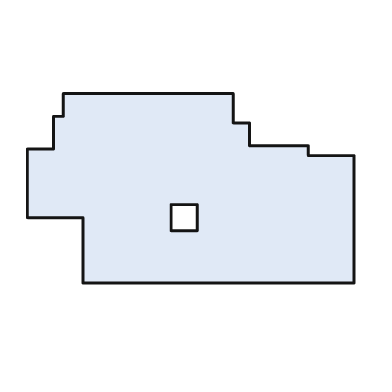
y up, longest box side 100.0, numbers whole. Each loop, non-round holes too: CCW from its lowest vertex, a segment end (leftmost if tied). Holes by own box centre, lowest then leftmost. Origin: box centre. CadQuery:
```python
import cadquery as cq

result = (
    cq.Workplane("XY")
    .moveTo(-33.0, -29.0)
    .lineTo(50.0, -29.0)
    .lineTo(50.0, 10.0)
    .lineTo(36.0, 10.0)
    .lineTo(36.0, 13.0)
    .lineTo(18.0, 13.0)
    .lineTo(18.0, 20.0)
    .lineTo(13.0, 20.0)
    .lineTo(13.0, 29.0)
    .lineTo(-39.0, 29.0)
    .lineTo(-39.0, 22.0)
    .lineTo(-42.0, 22.0)
    .lineTo(-42.0, 12.0)
    .lineTo(-50.0, 12.0)
    .lineTo(-50.0, -9.0)
    .lineTo(-33.0, -9.0)
    .close()
    .moveTo(-6.0, -13.0)
    .lineTo(2.0, -13.0)
    .lineTo(2.0, -5.0)
    .lineTo(-6.0, -5.0)
    .close()
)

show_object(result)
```